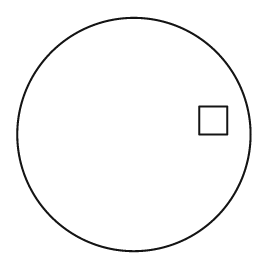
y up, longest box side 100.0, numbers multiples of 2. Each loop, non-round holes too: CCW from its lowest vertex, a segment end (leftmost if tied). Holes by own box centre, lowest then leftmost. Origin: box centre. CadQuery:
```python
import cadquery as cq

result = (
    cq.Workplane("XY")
    .moveTo(0.0, 0.0)
    .circle(50.0)
    .moveTo(28.0, 0.0)
    .lineTo(40.0, 0.0)
    .lineTo(40.0, 12.0)
    .lineTo(28.0, 12.0)
    .close()
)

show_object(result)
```